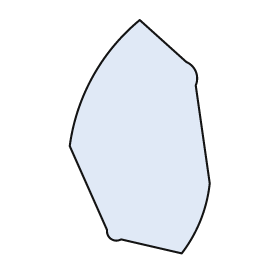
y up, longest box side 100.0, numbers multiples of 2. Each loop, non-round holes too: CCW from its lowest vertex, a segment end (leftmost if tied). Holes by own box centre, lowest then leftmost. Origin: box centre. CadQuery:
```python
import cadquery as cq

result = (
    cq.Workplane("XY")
    .moveTo(18.0, -50.0)
    .threePointArc((26.0, -36.0), (30.0, -20.0))
    .lineTo(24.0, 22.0)
    .threePointArc((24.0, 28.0), (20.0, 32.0))
    .lineTo(0.0, 50.0)
    .threePointArc((-20.0, 26.0), (-30.0, -4.0))
    .lineTo(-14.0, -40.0)
    .threePointArc((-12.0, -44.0), (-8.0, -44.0))
    .close()
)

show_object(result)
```